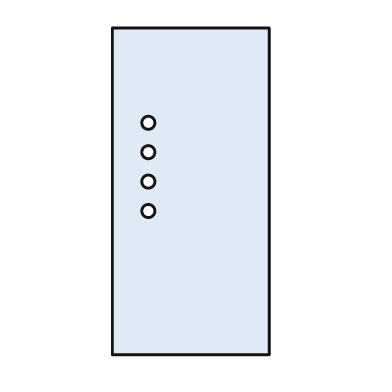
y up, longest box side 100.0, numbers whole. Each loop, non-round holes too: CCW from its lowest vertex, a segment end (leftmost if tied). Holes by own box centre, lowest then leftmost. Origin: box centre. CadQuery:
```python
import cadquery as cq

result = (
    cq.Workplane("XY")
    .moveTo(-24.0, -50.0)
    .lineTo(24.0, -50.0)
    .lineTo(24.0, 50.0)
    .lineTo(-24.0, 50.0)
    .close()
    .moveTo(-13.0, -6.0)
    .circle(2.0)
    .moveTo(-13.0, 3.0)
    .circle(2.0)
    .moveTo(-13.0, 12.0)
    .circle(2.0)
    .moveTo(-13.0, 21.0)
    .circle(2.0)
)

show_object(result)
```